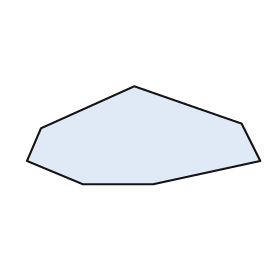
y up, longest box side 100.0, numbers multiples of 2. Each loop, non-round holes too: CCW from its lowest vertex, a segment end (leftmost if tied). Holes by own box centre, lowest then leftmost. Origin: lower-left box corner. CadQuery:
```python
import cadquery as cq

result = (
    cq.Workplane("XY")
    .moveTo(24.0, 0.0)
    .lineTo(54.0, 0.0)
    .lineTo(100.0, 10.0)
    .lineTo(92.0, 26.0)
    .lineTo(46.0, 42.0)
    .lineTo(6.0, 24.0)
    .lineTo(0.0, 10.0)
    .close()
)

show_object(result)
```